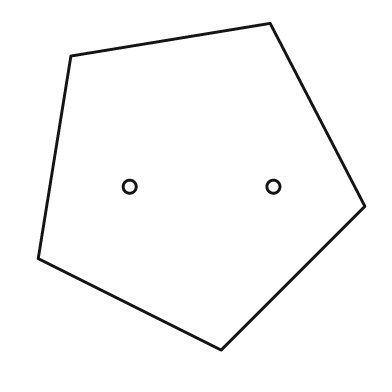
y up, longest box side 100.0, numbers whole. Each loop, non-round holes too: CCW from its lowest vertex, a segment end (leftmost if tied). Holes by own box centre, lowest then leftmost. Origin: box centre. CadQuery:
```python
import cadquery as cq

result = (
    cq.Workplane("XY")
    .moveTo(6.0, -50.0)
    .lineTo(50.0, -6.0)
    .lineTo(21.0, 50.0)
    .lineTo(-40.0, 40.0)
    .lineTo(-50.0, -22.0)
    .close()
    .moveTo(-22.0, 0.0)
    .circle(2.0)
    .moveTo(22.0, 0.0)
    .circle(2.0)
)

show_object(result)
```